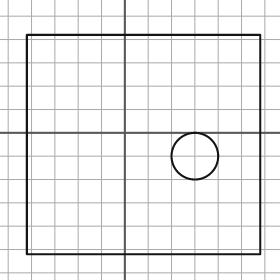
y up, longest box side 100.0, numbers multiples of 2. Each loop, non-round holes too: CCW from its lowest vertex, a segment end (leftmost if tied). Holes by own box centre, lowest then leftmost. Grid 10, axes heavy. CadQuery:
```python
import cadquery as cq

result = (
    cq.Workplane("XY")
    .moveTo(-42.0, -52.0)
    .lineTo(58.0, -52.0)
    .lineTo(58.0, 42.0)
    .lineTo(-42.0, 42.0)
    .close()
    .moveTo(30.0, -10.0)
    .circle(10.0)
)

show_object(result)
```